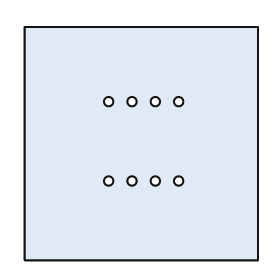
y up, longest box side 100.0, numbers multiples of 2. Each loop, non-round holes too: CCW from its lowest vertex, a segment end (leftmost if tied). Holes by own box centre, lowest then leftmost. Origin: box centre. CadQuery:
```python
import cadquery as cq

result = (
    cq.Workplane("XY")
    .moveTo(-50.0, -50.0)
    .lineTo(50.0, -50.0)
    .lineTo(50.0, 50.0)
    .lineTo(-50.0, 50.0)
    .close()
    .moveTo(-14.0, -16.0)
    .circle(2.0)
    .moveTo(-4.0, -16.0)
    .circle(2.0)
    .moveTo(6.0, -16.0)
    .circle(2.0)
    .moveTo(16.0, -16.0)
    .circle(2.0)
    .moveTo(-14.0, 18.0)
    .circle(2.0)
    .moveTo(-4.0, 18.0)
    .circle(2.0)
    .moveTo(6.0, 18.0)
    .circle(2.0)
    .moveTo(16.0, 18.0)
    .circle(2.0)
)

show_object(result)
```